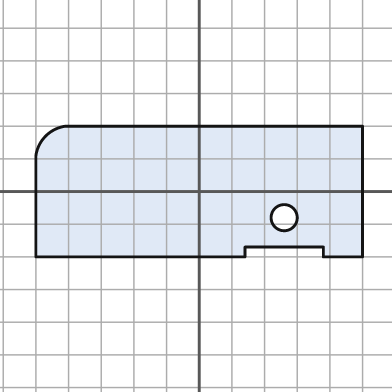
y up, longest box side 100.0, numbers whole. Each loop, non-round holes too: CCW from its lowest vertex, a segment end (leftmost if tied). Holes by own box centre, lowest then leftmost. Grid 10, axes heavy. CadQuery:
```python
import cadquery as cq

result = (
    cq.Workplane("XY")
    .moveTo(-50.0, -20.0)
    .lineTo(14.0, -20.0)
    .lineTo(14.0, -17.0)
    .lineTo(38.0, -17.0)
    .lineTo(38.0, -20.0)
    .lineTo(50.0, -20.0)
    .lineTo(50.0, 20.0)
    .lineTo(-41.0, 20.0)
    .threePointArc((-47.0, 17.0), (-50.0, 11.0))
    .close()
    .moveTo(26.0, -8.0)
    .circle(4.0)
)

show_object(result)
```